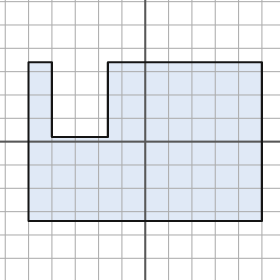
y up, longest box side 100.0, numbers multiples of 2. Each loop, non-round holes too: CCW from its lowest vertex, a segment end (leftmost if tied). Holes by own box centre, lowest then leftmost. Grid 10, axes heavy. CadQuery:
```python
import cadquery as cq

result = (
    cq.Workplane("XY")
    .moveTo(-50.0, -34.0)
    .lineTo(50.0, -34.0)
    .lineTo(50.0, 34.0)
    .lineTo(-16.0, 34.0)
    .lineTo(-16.0, 2.0)
    .lineTo(-40.0, 2.0)
    .lineTo(-40.0, 34.0)
    .lineTo(-50.0, 34.0)
    .close()
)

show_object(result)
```